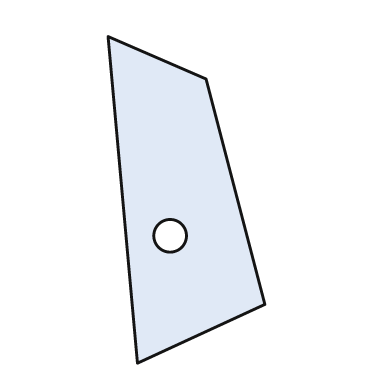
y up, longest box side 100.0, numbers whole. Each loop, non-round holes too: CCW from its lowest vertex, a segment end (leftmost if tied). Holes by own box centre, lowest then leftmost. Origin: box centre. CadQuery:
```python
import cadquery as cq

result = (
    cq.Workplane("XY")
    .moveTo(-15.0, -50.0)
    .lineTo(24.0, -32.0)
    .lineTo(6.0, 37.0)
    .lineTo(-24.0, 50.0)
    .close()
    .moveTo(-5.0, -11.0)
    .circle(5.0)
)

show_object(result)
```